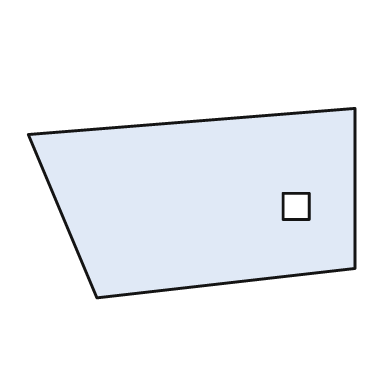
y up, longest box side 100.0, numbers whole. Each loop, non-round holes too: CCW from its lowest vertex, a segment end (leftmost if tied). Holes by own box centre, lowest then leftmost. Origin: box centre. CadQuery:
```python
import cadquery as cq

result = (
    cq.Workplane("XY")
    .moveTo(-29.0, -29.0)
    .lineTo(50.0, -20.0)
    .lineTo(50.0, 29.0)
    .lineTo(-50.0, 21.0)
    .close()
    .moveTo(28.0, -5.0)
    .lineTo(36.0, -5.0)
    .lineTo(36.0, 3.0)
    .lineTo(28.0, 3.0)
    .close()
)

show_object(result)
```